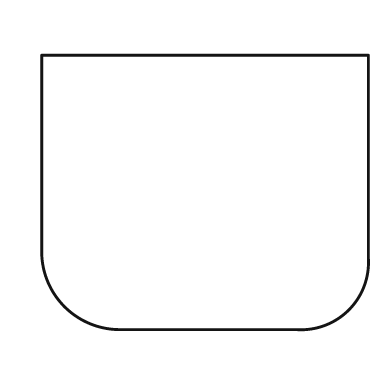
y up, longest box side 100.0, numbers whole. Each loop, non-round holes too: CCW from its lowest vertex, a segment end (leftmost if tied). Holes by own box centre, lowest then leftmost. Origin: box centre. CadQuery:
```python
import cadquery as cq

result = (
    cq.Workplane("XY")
    .moveTo(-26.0, -42.0)
    .lineTo(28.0, -42.0)
    .threePointArc((44.0, -36.0), (50.0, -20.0))
    .lineTo(50.0, 42.0)
    .lineTo(-50.0, 42.0)
    .lineTo(-50.0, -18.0)
    .threePointArc((-43.0, -35.0), (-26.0, -42.0))
    .close()
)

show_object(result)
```